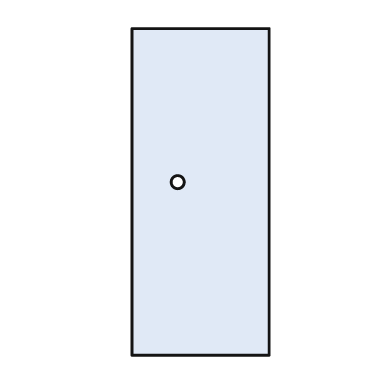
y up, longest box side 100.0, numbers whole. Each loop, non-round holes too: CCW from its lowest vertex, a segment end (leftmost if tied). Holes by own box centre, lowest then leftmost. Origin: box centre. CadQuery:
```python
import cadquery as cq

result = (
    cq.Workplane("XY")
    .moveTo(-21.0, -50.0)
    .lineTo(21.0, -50.0)
    .lineTo(21.0, 50.0)
    .lineTo(-21.0, 50.0)
    .close()
    .moveTo(-7.0, 3.0)
    .circle(2.0)
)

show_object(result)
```